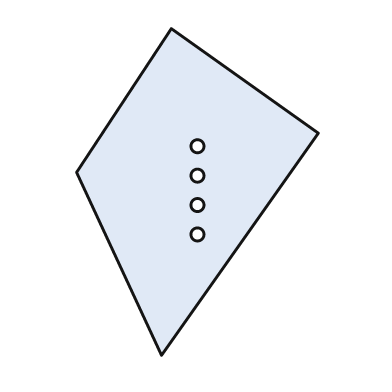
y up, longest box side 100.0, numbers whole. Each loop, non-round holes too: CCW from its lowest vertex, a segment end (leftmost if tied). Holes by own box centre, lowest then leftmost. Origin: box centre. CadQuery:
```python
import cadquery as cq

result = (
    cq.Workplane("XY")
    .moveTo(-11.0, -50.0)
    .lineTo(37.0, 18.0)
    .lineTo(-8.0, 50.0)
    .lineTo(-37.0, 6.0)
    .close()
    .moveTo(0.0, -13.0)
    .circle(2.0)
    .moveTo(0.0, -4.0)
    .circle(2.0)
    .moveTo(0.0, 5.0)
    .circle(2.0)
    .moveTo(0.0, 14.0)
    .circle(2.0)
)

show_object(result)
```